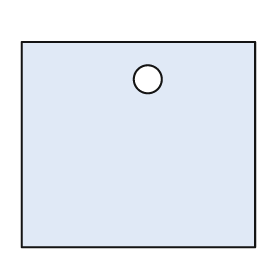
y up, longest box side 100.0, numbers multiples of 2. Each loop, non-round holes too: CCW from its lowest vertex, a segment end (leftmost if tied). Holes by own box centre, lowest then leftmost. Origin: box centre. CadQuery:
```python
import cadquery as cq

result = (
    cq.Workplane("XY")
    .moveTo(-50.0, -44.0)
    .lineTo(50.0, -44.0)
    .lineTo(50.0, 44.0)
    .lineTo(-50.0, 44.0)
    .close()
    .moveTo(4.0, 28.0)
    .circle(6.0)
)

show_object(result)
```